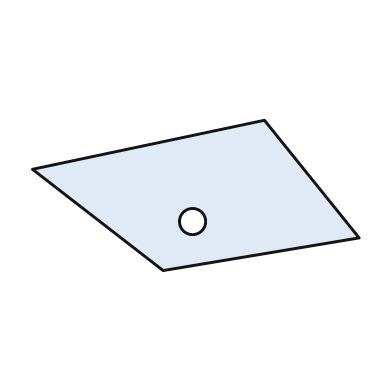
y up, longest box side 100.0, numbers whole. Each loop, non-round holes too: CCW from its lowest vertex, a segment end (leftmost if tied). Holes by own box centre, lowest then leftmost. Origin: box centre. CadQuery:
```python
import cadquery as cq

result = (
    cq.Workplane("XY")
    .moveTo(-10.0, -23.0)
    .lineTo(50.0, -13.0)
    .lineTo(21.0, 23.0)
    .lineTo(-50.0, 8.0)
    .close()
    .moveTo(-1.0, -8.0)
    .circle(4.0)
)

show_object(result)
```